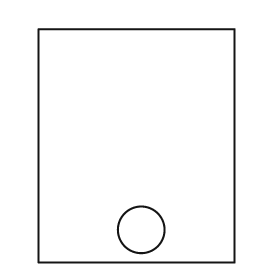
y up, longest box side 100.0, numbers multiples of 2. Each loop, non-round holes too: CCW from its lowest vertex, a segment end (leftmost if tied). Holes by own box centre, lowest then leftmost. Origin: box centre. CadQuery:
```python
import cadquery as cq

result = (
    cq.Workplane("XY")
    .moveTo(-42.0, -50.0)
    .lineTo(42.0, -50.0)
    .lineTo(42.0, 50.0)
    .lineTo(-42.0, 50.0)
    .close()
    .moveTo(2.0, -36.0)
    .circle(10.0)
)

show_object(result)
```